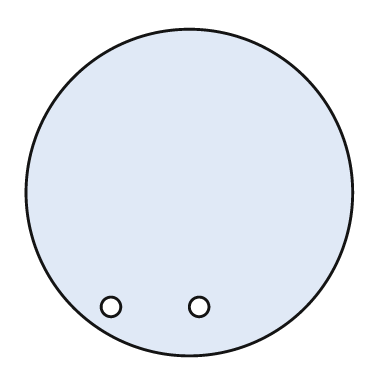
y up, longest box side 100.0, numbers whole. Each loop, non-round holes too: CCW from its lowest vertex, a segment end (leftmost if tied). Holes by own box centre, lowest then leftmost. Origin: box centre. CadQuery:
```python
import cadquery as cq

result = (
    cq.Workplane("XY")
    .moveTo(0.0, 0.0)
    .circle(50.0)
    .moveTo(-24.0, -35.0)
    .circle(3.0)
    .moveTo(3.0, -35.0)
    .circle(3.0)
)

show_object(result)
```